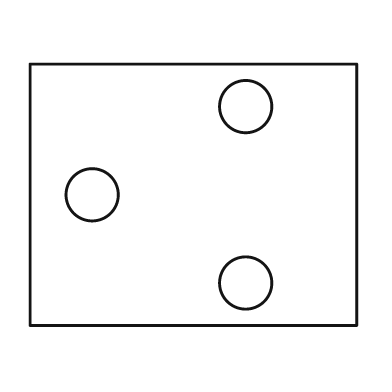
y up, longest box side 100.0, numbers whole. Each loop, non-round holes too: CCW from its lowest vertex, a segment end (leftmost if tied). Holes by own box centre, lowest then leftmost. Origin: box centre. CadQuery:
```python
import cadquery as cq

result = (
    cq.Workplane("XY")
    .moveTo(-50.0, -40.0)
    .lineTo(50.0, -40.0)
    .lineTo(50.0, 40.0)
    .lineTo(-50.0, 40.0)
    .close()
    .moveTo(16.0, -27.0)
    .circle(8.0)
    .moveTo(-31.0, 0.0)
    .circle(8.0)
    .moveTo(16.0, 27.0)
    .circle(8.0)
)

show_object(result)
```